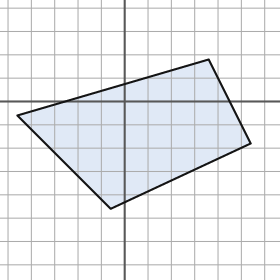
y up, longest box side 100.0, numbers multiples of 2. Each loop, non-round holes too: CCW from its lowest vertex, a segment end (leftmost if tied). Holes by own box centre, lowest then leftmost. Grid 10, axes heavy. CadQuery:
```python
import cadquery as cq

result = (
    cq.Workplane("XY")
    .moveTo(-6.0, -46.0)
    .lineTo(54.0, -18.0)
    .lineTo(36.0, 18.0)
    .lineTo(-46.0, -6.0)
    .close()
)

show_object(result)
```